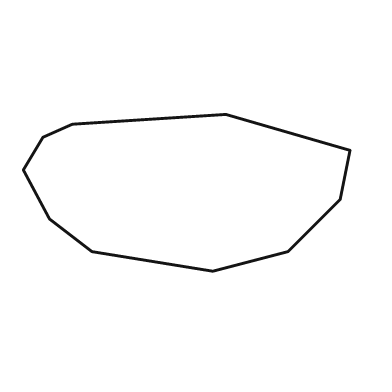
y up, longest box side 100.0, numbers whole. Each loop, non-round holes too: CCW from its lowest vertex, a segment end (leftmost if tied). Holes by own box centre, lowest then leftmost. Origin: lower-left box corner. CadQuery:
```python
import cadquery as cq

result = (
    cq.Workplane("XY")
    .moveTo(58.0, 0.0)
    .lineTo(81.0, 6.0)
    .lineTo(97.0, 22.0)
    .lineTo(100.0, 37.0)
    .lineTo(62.0, 48.0)
    .lineTo(15.0, 45.0)
    .lineTo(6.0, 41.0)
    .lineTo(0.0, 31.0)
    .lineTo(8.0, 16.0)
    .lineTo(21.0, 6.0)
    .close()
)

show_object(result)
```